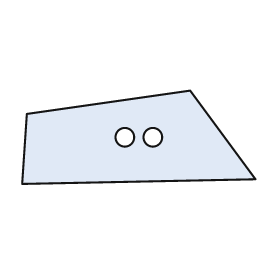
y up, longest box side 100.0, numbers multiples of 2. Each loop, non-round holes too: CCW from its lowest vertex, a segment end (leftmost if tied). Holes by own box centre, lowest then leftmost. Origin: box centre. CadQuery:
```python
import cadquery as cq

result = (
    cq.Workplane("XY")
    .moveTo(-50.0, -20.0)
    .lineTo(50.0, -18.0)
    .lineTo(22.0, 20.0)
    .lineTo(-48.0, 10.0)
    .close()
    .moveTo(-6.0, 0.0)
    .circle(4.0)
    .moveTo(6.0, 0.0)
    .circle(4.0)
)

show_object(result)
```